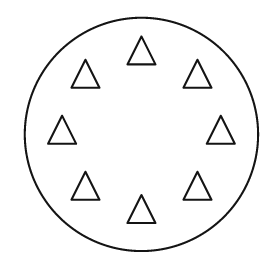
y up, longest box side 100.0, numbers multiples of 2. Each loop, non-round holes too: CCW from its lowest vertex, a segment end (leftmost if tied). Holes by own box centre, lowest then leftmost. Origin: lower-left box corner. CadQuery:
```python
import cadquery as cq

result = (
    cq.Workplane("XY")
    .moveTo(50.0, 50.0)
    .circle(50.0)
    .moveTo(44.0, 12.0)
    .lineTo(56.0, 12.0)
    .lineTo(50.0, 24.0)
    .close()
    .moveTo(20.0, 22.0)
    .lineTo(32.0, 22.0)
    .lineTo(26.0, 34.0)
    .close()
    .moveTo(68.0, 22.0)
    .lineTo(80.0, 22.0)
    .lineTo(74.0, 34.0)
    .close()
    .moveTo(10.0, 46.0)
    .lineTo(22.0, 46.0)
    .lineTo(16.0, 58.0)
    .close()
    .moveTo(78.0, 46.0)
    .lineTo(90.0, 46.0)
    .lineTo(84.0, 58.0)
    .close()
    .moveTo(20.0, 70.0)
    .lineTo(32.0, 70.0)
    .lineTo(26.0, 82.0)
    .close()
    .moveTo(68.0, 70.0)
    .lineTo(80.0, 70.0)
    .lineTo(74.0, 82.0)
    .close()
    .moveTo(44.0, 80.0)
    .lineTo(56.0, 80.0)
    .lineTo(50.0, 92.0)
    .close()
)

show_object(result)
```